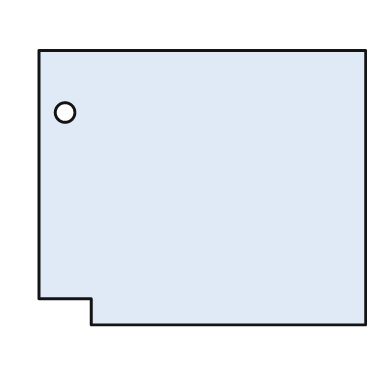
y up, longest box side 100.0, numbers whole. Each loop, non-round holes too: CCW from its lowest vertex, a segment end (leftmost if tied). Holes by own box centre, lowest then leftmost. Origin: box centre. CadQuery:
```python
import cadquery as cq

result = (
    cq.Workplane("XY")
    .moveTo(-34.0, -42.0)
    .lineTo(50.0, -42.0)
    .lineTo(50.0, 42.0)
    .lineTo(-50.0, 42.0)
    .lineTo(-50.0, -34.0)
    .lineTo(-34.0, -34.0)
    .close()
    .moveTo(-42.0, 23.0)
    .circle(3.0)
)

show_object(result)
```